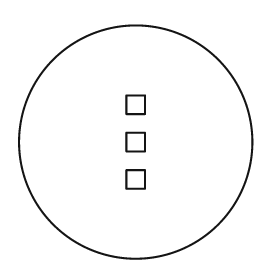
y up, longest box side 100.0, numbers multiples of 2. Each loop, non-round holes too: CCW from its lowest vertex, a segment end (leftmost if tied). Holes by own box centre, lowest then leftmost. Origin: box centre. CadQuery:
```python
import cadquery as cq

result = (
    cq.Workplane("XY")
    .moveTo(0.0, 0.0)
    .circle(50.0)
    .moveTo(-4.0, -20.0)
    .lineTo(4.0, -20.0)
    .lineTo(4.0, -12.0)
    .lineTo(-4.0, -12.0)
    .close()
    .moveTo(-4.0, -4.0)
    .lineTo(4.0, -4.0)
    .lineTo(4.0, 4.0)
    .lineTo(-4.0, 4.0)
    .close()
    .moveTo(-4.0, 12.0)
    .lineTo(4.0, 12.0)
    .lineTo(4.0, 20.0)
    .lineTo(-4.0, 20.0)
    .close()
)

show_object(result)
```